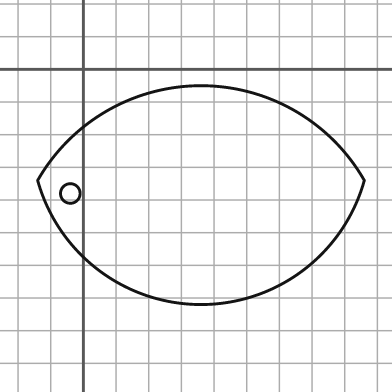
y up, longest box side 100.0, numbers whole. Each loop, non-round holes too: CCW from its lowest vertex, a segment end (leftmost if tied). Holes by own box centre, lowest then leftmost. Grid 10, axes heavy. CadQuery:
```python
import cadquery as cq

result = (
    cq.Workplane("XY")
    .moveTo(-14.0, -34.0)
    .threePointArc((36.0, -72.0), (86.0, -34.0))
    .threePointArc((36.0, -5.0), (-14.0, -34.0))
    .close()
    .moveTo(-4.0, -38.0)
    .circle(3.0)
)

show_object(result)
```